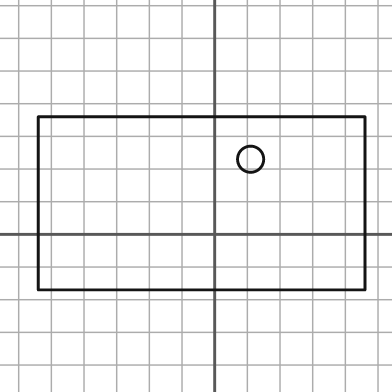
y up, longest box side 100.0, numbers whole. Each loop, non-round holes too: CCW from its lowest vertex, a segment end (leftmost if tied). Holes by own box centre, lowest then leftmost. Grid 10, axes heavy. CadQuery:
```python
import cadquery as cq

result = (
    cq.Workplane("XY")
    .moveTo(-54.0, -17.0)
    .lineTo(46.0, -17.0)
    .lineTo(46.0, 36.0)
    .lineTo(-54.0, 36.0)
    .close()
    .moveTo(11.0, 23.0)
    .circle(4.0)
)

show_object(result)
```